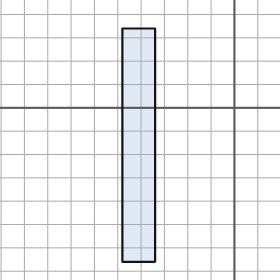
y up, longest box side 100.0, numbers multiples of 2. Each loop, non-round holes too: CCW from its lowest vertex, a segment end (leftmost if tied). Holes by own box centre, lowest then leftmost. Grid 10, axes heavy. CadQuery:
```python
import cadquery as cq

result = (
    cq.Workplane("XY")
    .moveTo(-48.0, -66.0)
    .lineTo(-34.0, -66.0)
    .lineTo(-34.0, 34.0)
    .lineTo(-48.0, 34.0)
    .close()
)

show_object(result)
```